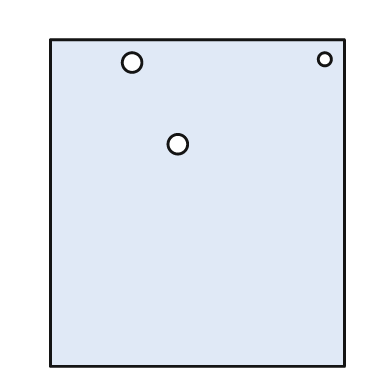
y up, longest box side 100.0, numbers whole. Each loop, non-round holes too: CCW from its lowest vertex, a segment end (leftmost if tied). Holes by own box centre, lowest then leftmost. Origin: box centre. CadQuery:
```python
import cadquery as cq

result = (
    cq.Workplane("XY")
    .moveTo(-45.0, -50.0)
    .lineTo(45.0, -50.0)
    .lineTo(45.0, 50.0)
    .lineTo(-45.0, 50.0)
    .close()
    .moveTo(-6.0, 18.0)
    .circle(3.0)
    .moveTo(-20.0, 43.0)
    .circle(3.0)
    .moveTo(39.0, 44.0)
    .circle(2.0)
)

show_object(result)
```